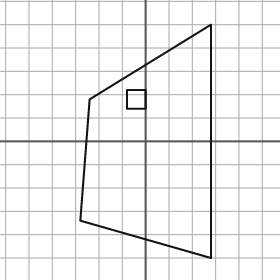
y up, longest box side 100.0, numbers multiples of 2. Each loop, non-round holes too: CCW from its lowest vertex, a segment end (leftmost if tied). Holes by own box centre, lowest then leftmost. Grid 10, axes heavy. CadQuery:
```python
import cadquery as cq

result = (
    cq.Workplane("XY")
    .moveTo(28.0, -50.0)
    .lineTo(28.0, 50.0)
    .lineTo(-24.0, 18.0)
    .lineTo(-28.0, -34.0)
    .close()
    .moveTo(-8.0, 14.0)
    .lineTo(0.0, 14.0)
    .lineTo(0.0, 22.0)
    .lineTo(-8.0, 22.0)
    .close()
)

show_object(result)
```